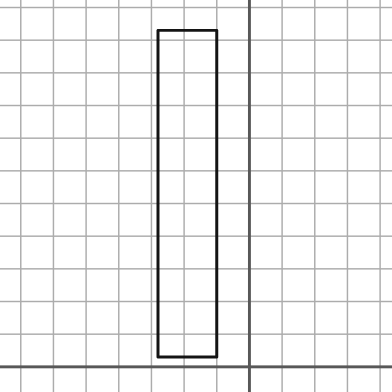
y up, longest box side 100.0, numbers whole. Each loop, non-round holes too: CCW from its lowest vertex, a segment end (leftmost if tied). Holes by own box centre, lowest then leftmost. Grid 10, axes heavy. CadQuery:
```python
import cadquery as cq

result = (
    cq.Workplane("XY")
    .moveTo(-28.0, 3.0)
    .lineTo(-10.0, 3.0)
    .lineTo(-10.0, 103.0)
    .lineTo(-28.0, 103.0)
    .close()
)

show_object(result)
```